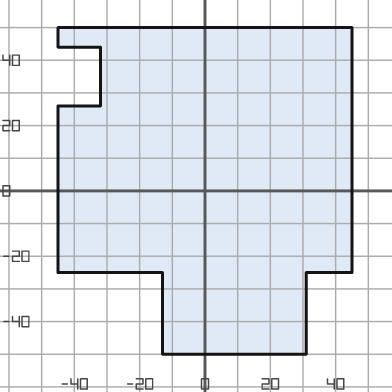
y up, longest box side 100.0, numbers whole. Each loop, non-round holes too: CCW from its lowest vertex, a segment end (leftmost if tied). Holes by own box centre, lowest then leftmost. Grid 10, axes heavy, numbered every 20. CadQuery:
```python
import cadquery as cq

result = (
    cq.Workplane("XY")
    .moveTo(-13.0, -50.0)
    .lineTo(31.0, -50.0)
    .lineTo(31.0, -25.0)
    .lineTo(45.0, -25.0)
    .lineTo(45.0, 50.0)
    .lineTo(-45.0, 50.0)
    .lineTo(-45.0, 44.0)
    .lineTo(-32.0, 44.0)
    .lineTo(-32.0, 26.0)
    .lineTo(-45.0, 26.0)
    .lineTo(-45.0, -25.0)
    .lineTo(-13.0, -25.0)
    .close()
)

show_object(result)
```